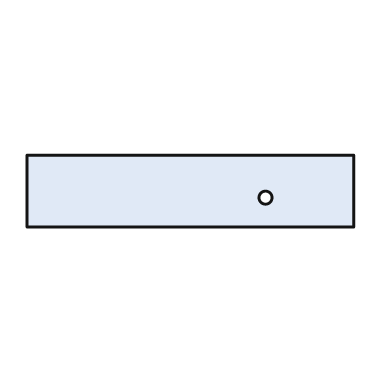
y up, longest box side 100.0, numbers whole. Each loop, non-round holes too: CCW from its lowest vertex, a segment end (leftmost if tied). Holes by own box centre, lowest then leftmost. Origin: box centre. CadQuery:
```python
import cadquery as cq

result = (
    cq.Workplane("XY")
    .moveTo(-50.0, -11.0)
    .lineTo(50.0, -11.0)
    .lineTo(50.0, 11.0)
    .lineTo(-50.0, 11.0)
    .close()
    .moveTo(23.0, -2.0)
    .circle(2.0)
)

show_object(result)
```